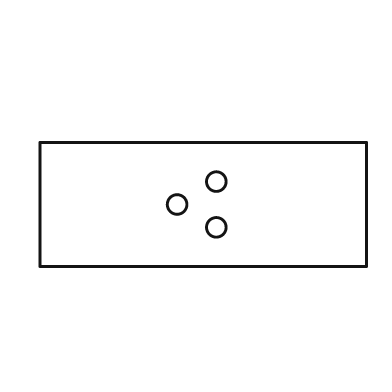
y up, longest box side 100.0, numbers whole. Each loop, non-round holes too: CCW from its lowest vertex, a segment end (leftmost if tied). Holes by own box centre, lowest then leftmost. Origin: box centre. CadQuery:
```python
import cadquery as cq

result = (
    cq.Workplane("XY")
    .moveTo(-50.0, -19.0)
    .lineTo(50.0, -19.0)
    .lineTo(50.0, 19.0)
    .lineTo(-50.0, 19.0)
    .close()
    .moveTo(4.0, -7.0)
    .circle(3.0)
    .moveTo(-8.0, 0.0)
    .circle(3.0)
    .moveTo(4.0, 7.0)
    .circle(3.0)
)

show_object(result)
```